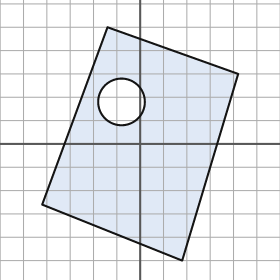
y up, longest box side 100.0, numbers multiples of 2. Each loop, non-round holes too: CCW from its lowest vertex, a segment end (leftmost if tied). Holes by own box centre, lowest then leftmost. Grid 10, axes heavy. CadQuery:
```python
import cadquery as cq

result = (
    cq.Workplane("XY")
    .moveTo(18.0, -50.0)
    .lineTo(42.0, 30.0)
    .lineTo(-14.0, 50.0)
    .lineTo(-42.0, -26.0)
    .close()
    .moveTo(-8.0, 18.0)
    .circle(10.0)
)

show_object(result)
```